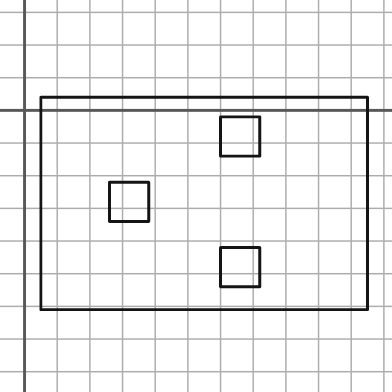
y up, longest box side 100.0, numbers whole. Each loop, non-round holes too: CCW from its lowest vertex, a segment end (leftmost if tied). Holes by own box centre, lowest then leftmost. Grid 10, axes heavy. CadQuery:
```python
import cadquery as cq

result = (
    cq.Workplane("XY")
    .moveTo(5.0, -61.0)
    .lineTo(105.0, -61.0)
    .lineTo(105.0, 4.0)
    .lineTo(5.0, 4.0)
    .close()
    .moveTo(60.0, -54.0)
    .lineTo(72.0, -54.0)
    .lineTo(72.0, -42.0)
    .lineTo(60.0, -42.0)
    .close()
    .moveTo(26.0, -34.0)
    .lineTo(38.0, -34.0)
    .lineTo(38.0, -22.0)
    .lineTo(26.0, -22.0)
    .close()
    .moveTo(60.0, -14.0)
    .lineTo(72.0, -14.0)
    .lineTo(72.0, -2.0)
    .lineTo(60.0, -2.0)
    .close()
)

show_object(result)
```